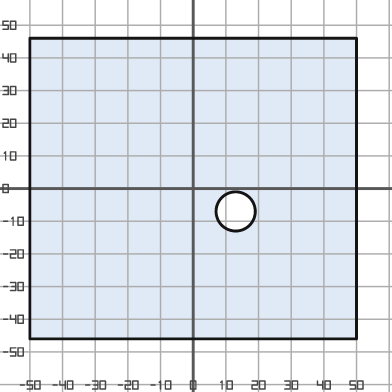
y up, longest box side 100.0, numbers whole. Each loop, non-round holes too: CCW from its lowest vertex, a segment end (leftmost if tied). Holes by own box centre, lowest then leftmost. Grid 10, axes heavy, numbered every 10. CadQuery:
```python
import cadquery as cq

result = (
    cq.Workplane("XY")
    .moveTo(-50.0, -46.0)
    .lineTo(50.0, -46.0)
    .lineTo(50.0, 46.0)
    .lineTo(-50.0, 46.0)
    .close()
    .moveTo(13.0, -7.0)
    .circle(6.0)
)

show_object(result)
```